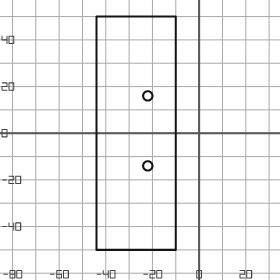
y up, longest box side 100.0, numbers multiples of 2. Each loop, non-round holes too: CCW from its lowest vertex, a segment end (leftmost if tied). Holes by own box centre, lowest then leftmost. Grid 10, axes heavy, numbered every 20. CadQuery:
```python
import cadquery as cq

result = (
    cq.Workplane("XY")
    .moveTo(-44.0, -50.0)
    .lineTo(-10.0, -50.0)
    .lineTo(-10.0, 50.0)
    .lineTo(-44.0, 50.0)
    .close()
    .moveTo(-22.0, -14.0)
    .circle(2.0)
    .moveTo(-22.0, 16.0)
    .circle(2.0)
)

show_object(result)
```